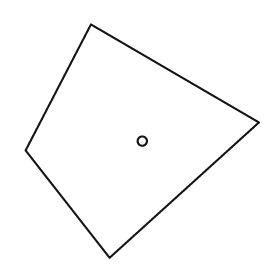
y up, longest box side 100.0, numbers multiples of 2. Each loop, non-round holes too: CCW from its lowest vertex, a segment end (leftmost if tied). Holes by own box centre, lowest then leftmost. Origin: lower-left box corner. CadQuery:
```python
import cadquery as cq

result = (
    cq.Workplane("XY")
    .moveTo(36.0, 0.0)
    .lineTo(100.0, 58.0)
    .lineTo(28.0, 100.0)
    .lineTo(0.0, 46.0)
    .close()
    .moveTo(50.0, 50.0)
    .circle(2.0)
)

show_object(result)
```